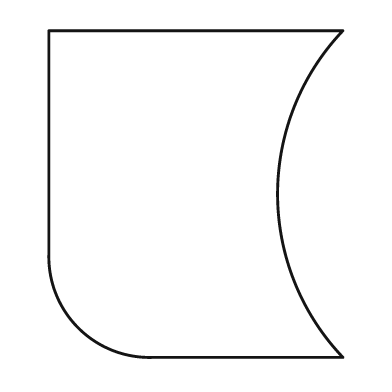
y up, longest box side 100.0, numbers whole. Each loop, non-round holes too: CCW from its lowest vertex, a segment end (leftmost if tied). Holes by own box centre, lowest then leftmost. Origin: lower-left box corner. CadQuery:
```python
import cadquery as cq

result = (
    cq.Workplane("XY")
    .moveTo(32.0, 0.0)
    .lineTo(90.0, 0.0)
    .threePointArc((70.0, 50.0), (90.0, 100.0))
    .lineTo(0.0, 100.0)
    .lineTo(0.0, 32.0)
    .threePointArc((9.0, 9.0), (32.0, 0.0))
    .close()
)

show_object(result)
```